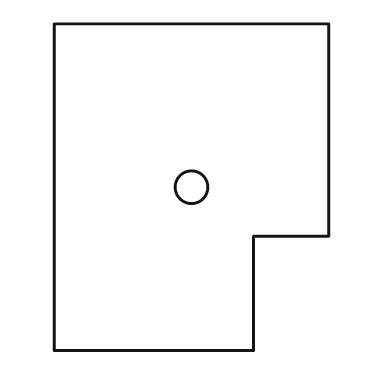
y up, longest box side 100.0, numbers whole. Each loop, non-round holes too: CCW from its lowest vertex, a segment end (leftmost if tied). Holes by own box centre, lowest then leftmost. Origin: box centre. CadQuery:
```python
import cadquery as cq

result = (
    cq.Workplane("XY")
    .moveTo(-42.0, -50.0)
    .lineTo(19.0, -50.0)
    .lineTo(19.0, -15.0)
    .lineTo(42.0, -15.0)
    .lineTo(42.0, 50.0)
    .lineTo(-42.0, 50.0)
    .close()
    .moveTo(0.0, 0.0)
    .circle(5.0)
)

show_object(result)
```